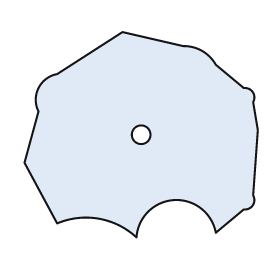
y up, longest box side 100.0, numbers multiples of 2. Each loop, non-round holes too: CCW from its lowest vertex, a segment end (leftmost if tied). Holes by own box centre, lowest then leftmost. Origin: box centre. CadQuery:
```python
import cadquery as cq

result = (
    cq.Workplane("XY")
    .moveTo(-2.0, -44.0)
    .threePointArc((14.0, -28.0), (32.0, -42.0))
    .lineTo(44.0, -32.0)
    .threePointArc((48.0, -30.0), (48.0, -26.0))
    .lineTo(50.0, 2.0)
    .lineTo(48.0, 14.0)
    .threePointArc((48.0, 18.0), (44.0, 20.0))
    .lineTo(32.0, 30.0)
    .threePointArc((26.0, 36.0), (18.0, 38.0))
    .lineTo(-8.0, 44.0)
    .lineTo(-36.0, 26.0)
    .threePointArc((-44.0, 20.0), (-44.0, 10.0))
    .lineTo(-50.0, -12.0)
    .lineTo(-36.0, -38.0)
    .threePointArc((-18.0, -36.0), (-2.0, -44.0))
    .close()
    .moveTo(0.0, 0.0)
    .circle(4.0)
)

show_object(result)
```